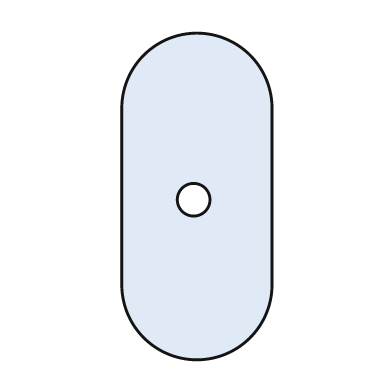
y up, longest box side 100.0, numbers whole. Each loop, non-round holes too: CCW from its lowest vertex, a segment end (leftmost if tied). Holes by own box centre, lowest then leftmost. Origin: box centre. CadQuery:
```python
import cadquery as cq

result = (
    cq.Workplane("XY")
    .moveTo(-23.0, -27.0)
    .threePointArc((0.0, -50.0), (23.0, -27.0))
    .lineTo(23.0, 27.0)
    .threePointArc((0.0, 50.0), (-23.0, 27.0))
    .close()
    .moveTo(-1.0, -1.0)
    .circle(5.0)
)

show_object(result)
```